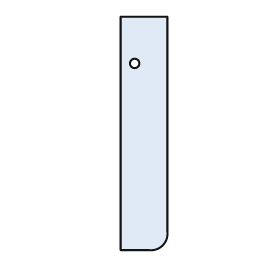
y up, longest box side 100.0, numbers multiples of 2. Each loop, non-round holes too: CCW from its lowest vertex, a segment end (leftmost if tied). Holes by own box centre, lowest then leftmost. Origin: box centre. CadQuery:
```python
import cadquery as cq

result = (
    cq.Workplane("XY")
    .moveTo(-10.0, -50.0)
    .lineTo(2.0, -50.0)
    .threePointArc((8.0, -48.0), (10.0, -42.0))
    .lineTo(10.0, 50.0)
    .lineTo(-10.0, 50.0)
    .close()
    .moveTo(-4.0, 30.0)
    .circle(2.0)
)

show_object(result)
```